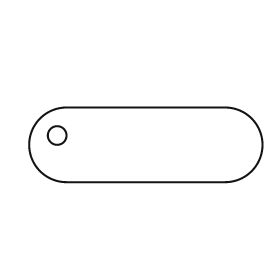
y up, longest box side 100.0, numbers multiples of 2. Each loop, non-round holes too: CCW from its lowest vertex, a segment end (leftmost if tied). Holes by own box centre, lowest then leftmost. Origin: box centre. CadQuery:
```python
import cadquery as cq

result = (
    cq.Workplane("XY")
    .moveTo(-34.0, -16.0)
    .lineTo(34.0, -16.0)
    .threePointArc((50.0, 0.0), (34.0, 16.0))
    .lineTo(-34.0, 16.0)
    .threePointArc((-50.0, 0.0), (-34.0, -16.0))
    .close()
    .moveTo(-38.0, 4.0)
    .circle(4.0)
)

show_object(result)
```